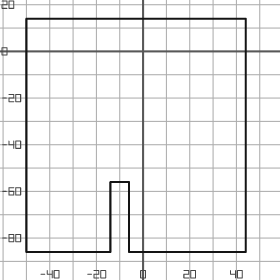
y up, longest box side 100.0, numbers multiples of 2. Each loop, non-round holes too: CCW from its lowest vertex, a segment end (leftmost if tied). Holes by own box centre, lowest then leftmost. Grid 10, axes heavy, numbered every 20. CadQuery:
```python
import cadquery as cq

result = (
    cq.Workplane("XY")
    .moveTo(-50.0, -86.0)
    .lineTo(-14.0, -86.0)
    .lineTo(-14.0, -56.0)
    .lineTo(-6.0, -56.0)
    .lineTo(-6.0, -86.0)
    .lineTo(44.0, -86.0)
    .lineTo(44.0, 14.0)
    .lineTo(-50.0, 14.0)
    .close()
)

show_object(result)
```